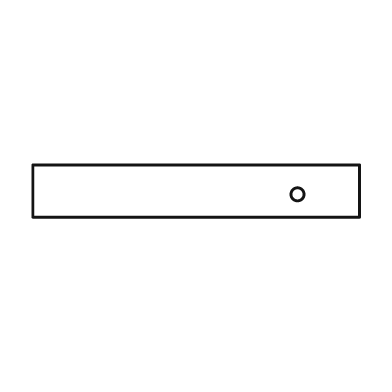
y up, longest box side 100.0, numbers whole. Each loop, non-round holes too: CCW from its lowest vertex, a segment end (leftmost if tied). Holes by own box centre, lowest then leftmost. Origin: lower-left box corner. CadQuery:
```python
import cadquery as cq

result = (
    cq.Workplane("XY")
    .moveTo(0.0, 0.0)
    .lineTo(100.0, 0.0)
    .lineTo(100.0, 16.0)
    .lineTo(0.0, 16.0)
    .close()
    .moveTo(81.0, 7.0)
    .circle(2.0)
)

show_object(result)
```